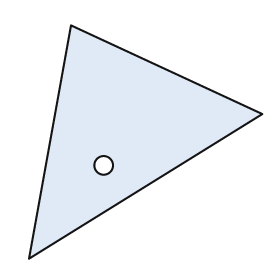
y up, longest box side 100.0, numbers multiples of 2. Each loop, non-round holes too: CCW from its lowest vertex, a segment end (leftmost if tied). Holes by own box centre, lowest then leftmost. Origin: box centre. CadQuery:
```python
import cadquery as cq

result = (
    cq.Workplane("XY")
    .moveTo(-50.0, -50.0)
    .lineTo(50.0, 12.0)
    .lineTo(-32.0, 50.0)
    .close()
    .moveTo(-18.0, -10.0)
    .circle(4.0)
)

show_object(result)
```